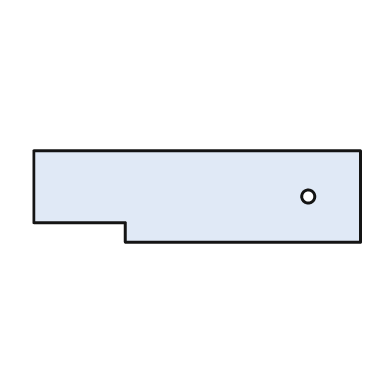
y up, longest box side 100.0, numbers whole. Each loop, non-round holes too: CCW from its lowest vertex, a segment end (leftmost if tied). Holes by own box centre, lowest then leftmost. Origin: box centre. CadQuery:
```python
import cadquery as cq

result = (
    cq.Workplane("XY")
    .moveTo(-22.0, -14.0)
    .lineTo(50.0, -14.0)
    .lineTo(50.0, 14.0)
    .lineTo(-50.0, 14.0)
    .lineTo(-50.0, -8.0)
    .lineTo(-22.0, -8.0)
    .close()
    .moveTo(34.0, 0.0)
    .circle(2.0)
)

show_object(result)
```